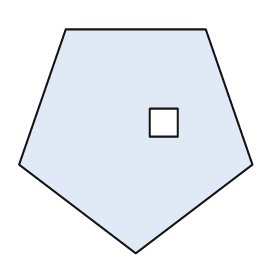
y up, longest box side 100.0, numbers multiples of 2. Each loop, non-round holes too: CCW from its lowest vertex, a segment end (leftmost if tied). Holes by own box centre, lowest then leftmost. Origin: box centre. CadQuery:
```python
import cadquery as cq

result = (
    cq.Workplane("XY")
    .moveTo(0.0, -48.0)
    .lineTo(50.0, -10.0)
    .lineTo(30.0, 48.0)
    .lineTo(-30.0, 48.0)
    .lineTo(-50.0, -10.0)
    .close()
    .moveTo(6.0, 2.0)
    .lineTo(18.0, 2.0)
    .lineTo(18.0, 14.0)
    .lineTo(6.0, 14.0)
    .close()
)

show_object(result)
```